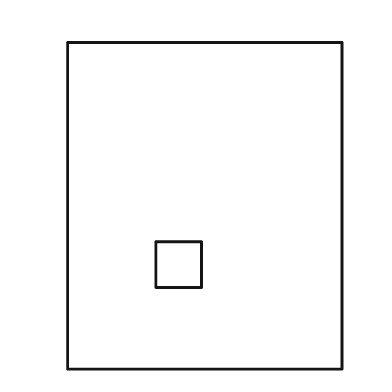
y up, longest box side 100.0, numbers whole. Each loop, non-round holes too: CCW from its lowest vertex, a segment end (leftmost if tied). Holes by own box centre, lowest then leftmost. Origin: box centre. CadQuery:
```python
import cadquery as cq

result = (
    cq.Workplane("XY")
    .moveTo(-42.0, -50.0)
    .lineTo(42.0, -50.0)
    .lineTo(42.0, 50.0)
    .lineTo(-42.0, 50.0)
    .close()
    .moveTo(-15.0, -25.0)
    .lineTo(-1.0, -25.0)
    .lineTo(-1.0, -11.0)
    .lineTo(-15.0, -11.0)
    .close()
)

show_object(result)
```